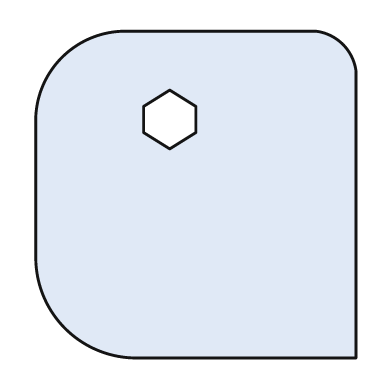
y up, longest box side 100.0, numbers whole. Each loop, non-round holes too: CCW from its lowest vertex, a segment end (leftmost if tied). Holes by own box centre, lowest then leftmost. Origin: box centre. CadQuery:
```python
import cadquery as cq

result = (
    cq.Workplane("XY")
    .moveTo(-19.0, -50.0)
    .lineTo(49.0, -50.0)
    .lineTo(49.0, 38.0)
    .threePointArc((45.0, 46.0), (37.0, 50.0))
    .lineTo(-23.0, 50.0)
    .threePointArc((-41.0, 42.0), (-49.0, 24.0))
    .lineTo(-49.0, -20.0)
    .threePointArc((-40.0, -41.0), (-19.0, -50.0))
    .close()
    .moveTo(-8.0, 14.0)
    .lineTo(0.0, 19.0)
    .lineTo(0.0, 27.0)
    .lineTo(-8.0, 32.0)
    .lineTo(-16.0, 27.0)
    .lineTo(-16.0, 19.0)
    .close()
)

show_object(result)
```